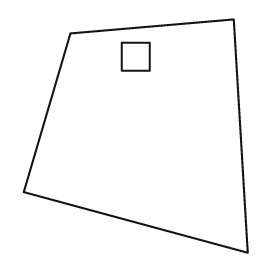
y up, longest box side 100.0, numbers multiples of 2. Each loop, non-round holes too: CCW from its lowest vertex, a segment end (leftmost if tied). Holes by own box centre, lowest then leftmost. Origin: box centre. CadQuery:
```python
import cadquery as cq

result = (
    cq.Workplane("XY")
    .moveTo(48.0, -50.0)
    .lineTo(42.0, 50.0)
    .lineTo(-28.0, 44.0)
    .lineTo(-48.0, -24.0)
    .close()
    .moveTo(-6.0, 28.0)
    .lineTo(6.0, 28.0)
    .lineTo(6.0, 40.0)
    .lineTo(-6.0, 40.0)
    .close()
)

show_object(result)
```